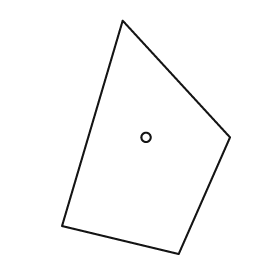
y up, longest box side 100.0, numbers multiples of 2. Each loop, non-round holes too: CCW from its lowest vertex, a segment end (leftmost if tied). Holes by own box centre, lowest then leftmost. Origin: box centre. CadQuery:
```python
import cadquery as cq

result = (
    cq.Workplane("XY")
    .moveTo(14.0, -50.0)
    .lineTo(36.0, 0.0)
    .lineTo(-10.0, 50.0)
    .lineTo(-36.0, -38.0)
    .close()
    .moveTo(0.0, 0.0)
    .circle(2.0)
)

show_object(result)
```